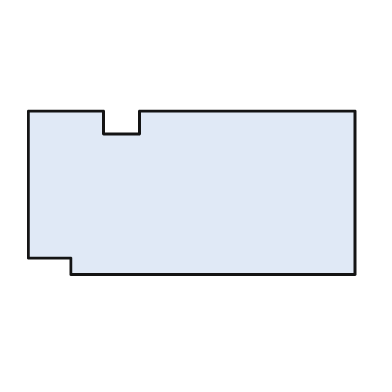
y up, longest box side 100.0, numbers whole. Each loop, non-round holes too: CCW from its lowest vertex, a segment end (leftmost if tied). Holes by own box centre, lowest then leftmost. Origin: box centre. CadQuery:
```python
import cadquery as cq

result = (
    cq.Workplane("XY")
    .moveTo(-37.0, -25.0)
    .lineTo(50.0, -25.0)
    .lineTo(50.0, 25.0)
    .lineTo(-16.0, 25.0)
    .lineTo(-16.0, 18.0)
    .lineTo(-27.0, 18.0)
    .lineTo(-27.0, 25.0)
    .lineTo(-50.0, 25.0)
    .lineTo(-50.0, -20.0)
    .lineTo(-37.0, -20.0)
    .close()
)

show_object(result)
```